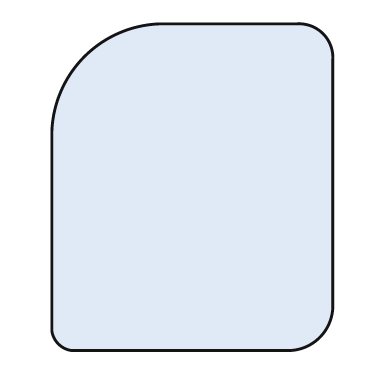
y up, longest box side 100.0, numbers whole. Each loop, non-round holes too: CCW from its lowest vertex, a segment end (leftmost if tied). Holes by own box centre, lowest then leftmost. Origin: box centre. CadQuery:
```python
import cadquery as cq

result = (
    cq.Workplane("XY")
    .moveTo(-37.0, -50.0)
    .lineTo(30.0, -50.0)
    .threePointArc((39.0, -46.0), (43.0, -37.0))
    .lineTo(43.0, 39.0)
    .threePointArc((40.0, 47.0), (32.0, 50.0))
    .lineTo(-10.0, 50.0)
    .threePointArc((-33.0, 40.0), (-43.0, 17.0))
    .lineTo(-43.0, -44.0)
    .threePointArc((-41.0, -48.0), (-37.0, -50.0))
    .close()
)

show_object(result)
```